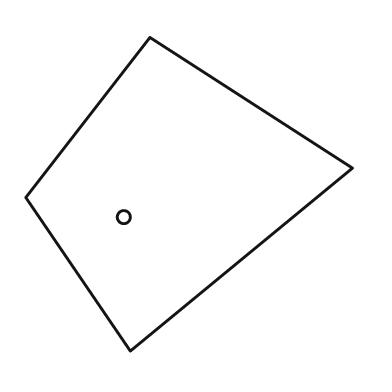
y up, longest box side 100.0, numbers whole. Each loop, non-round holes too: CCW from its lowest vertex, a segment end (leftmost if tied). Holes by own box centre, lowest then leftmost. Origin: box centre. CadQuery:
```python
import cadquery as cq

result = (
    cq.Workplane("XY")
    .moveTo(-18.0, -48.0)
    .lineTo(50.0, 8.0)
    .lineTo(-12.0, 48.0)
    .lineTo(-50.0, -1.0)
    .close()
    .moveTo(-20.0, -7.0)
    .circle(2.0)
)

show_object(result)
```